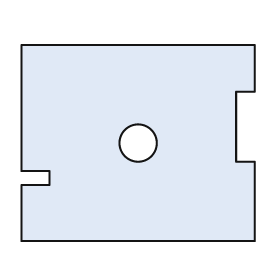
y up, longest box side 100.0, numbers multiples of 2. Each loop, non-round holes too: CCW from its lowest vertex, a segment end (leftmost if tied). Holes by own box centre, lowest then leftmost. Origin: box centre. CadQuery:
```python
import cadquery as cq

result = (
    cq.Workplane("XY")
    .moveTo(-50.0, -42.0)
    .lineTo(50.0, -42.0)
    .lineTo(50.0, -8.0)
    .lineTo(42.0, -8.0)
    .lineTo(42.0, 22.0)
    .lineTo(50.0, 22.0)
    .lineTo(50.0, 42.0)
    .lineTo(-50.0, 42.0)
    .lineTo(-50.0, -12.0)
    .lineTo(-38.0, -12.0)
    .lineTo(-38.0, -18.0)
    .lineTo(-50.0, -18.0)
    .close()
    .moveTo(0.0, 0.0)
    .circle(8.0)
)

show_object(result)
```